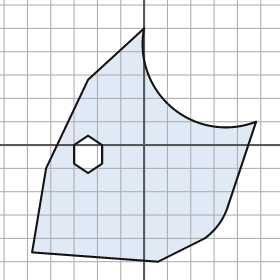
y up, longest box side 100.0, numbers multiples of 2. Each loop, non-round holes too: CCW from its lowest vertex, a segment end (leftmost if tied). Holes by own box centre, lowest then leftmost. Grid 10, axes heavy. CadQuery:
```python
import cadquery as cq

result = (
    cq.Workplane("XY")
    .moveTo(6.0, -50.0)
    .lineTo(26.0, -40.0)
    .threePointArc((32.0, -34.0), (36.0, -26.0))
    .lineTo(48.0, 10.0)
    .threePointArc((12.0, 16.0), (0.0, 50.0))
    .lineTo(-24.0, 28.0)
    .lineTo(-42.0, -10.0)
    .lineTo(-48.0, -46.0)
    .close()
    .moveTo(-24.0, -12.0)
    .lineTo(-18.0, -8.0)
    .lineTo(-18.0, 0.0)
    .lineTo(-24.0, 4.0)
    .lineTo(-30.0, 0.0)
    .lineTo(-30.0, -8.0)
    .close()
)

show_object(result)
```